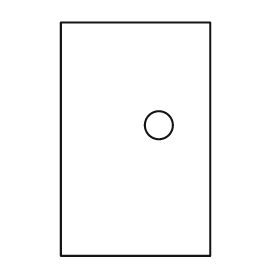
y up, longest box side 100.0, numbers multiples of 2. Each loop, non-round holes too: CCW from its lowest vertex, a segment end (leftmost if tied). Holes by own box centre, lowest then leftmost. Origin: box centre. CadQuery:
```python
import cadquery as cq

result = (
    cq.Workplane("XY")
    .moveTo(-32.0, -50.0)
    .lineTo(32.0, -50.0)
    .lineTo(32.0, 50.0)
    .lineTo(-32.0, 50.0)
    .close()
    .moveTo(10.0, 6.0)
    .circle(6.0)
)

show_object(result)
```